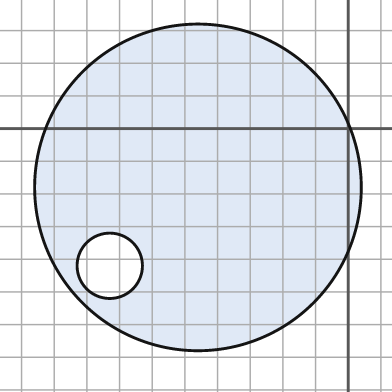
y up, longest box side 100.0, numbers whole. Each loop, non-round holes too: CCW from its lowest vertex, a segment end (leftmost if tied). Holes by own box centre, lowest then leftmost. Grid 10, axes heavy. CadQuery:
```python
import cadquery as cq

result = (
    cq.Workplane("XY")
    .moveTo(-46.0, -18.0)
    .circle(50.0)
    .moveTo(-73.0, -42.0)
    .circle(10.0)
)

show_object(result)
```